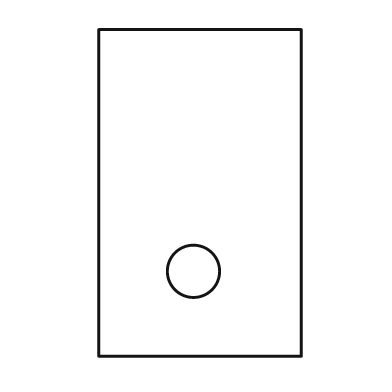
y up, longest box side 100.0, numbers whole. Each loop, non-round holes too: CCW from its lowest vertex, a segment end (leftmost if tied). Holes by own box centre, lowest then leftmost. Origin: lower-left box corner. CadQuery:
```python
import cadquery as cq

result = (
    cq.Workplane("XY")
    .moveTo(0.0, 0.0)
    .lineTo(62.0, 0.0)
    .lineTo(62.0, 100.0)
    .lineTo(0.0, 100.0)
    .close()
    .moveTo(29.0, 26.0)
    .circle(8.0)
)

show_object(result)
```